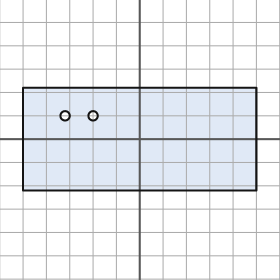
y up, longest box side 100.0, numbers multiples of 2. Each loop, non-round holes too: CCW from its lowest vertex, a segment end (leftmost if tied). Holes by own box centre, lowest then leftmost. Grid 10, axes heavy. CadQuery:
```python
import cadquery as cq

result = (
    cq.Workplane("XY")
    .moveTo(-50.0, -22.0)
    .lineTo(50.0, -22.0)
    .lineTo(50.0, 22.0)
    .lineTo(-50.0, 22.0)
    .close()
    .moveTo(-32.0, 10.0)
    .circle(2.0)
    .moveTo(-20.0, 10.0)
    .circle(2.0)
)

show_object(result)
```